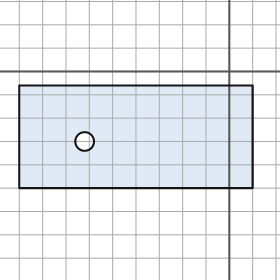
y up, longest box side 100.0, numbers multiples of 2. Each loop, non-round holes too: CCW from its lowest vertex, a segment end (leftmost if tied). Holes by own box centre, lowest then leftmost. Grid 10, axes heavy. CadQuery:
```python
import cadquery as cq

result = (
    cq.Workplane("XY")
    .moveTo(-90.0, -50.0)
    .lineTo(10.0, -50.0)
    .lineTo(10.0, -6.0)
    .lineTo(-90.0, -6.0)
    .close()
    .moveTo(-62.0, -30.0)
    .circle(4.0)
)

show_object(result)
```